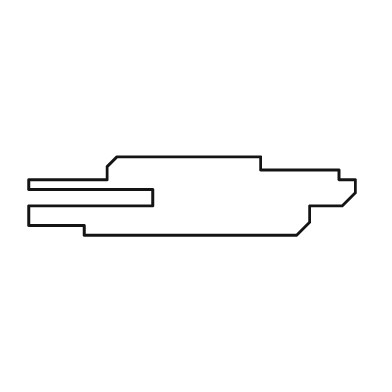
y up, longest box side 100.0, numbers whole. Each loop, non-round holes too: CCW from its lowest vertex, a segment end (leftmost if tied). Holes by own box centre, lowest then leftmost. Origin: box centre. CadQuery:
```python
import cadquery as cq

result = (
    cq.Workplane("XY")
    .moveTo(-33.0, -12.0)
    .lineTo(32.0, -12.0)
    .lineTo(36.0, -8.0)
    .lineTo(36.0, -3.0)
    .lineTo(46.0, -3.0)
    .lineTo(50.0, 1.0)
    .lineTo(50.0, 5.0)
    .lineTo(45.0, 5.0)
    .lineTo(45.0, 8.0)
    .lineTo(21.0, 8.0)
    .lineTo(21.0, 12.0)
    .lineTo(-23.0, 12.0)
    .lineTo(-26.0, 9.0)
    .lineTo(-26.0, 5.0)
    .lineTo(-50.0, 5.0)
    .lineTo(-50.0, 2.0)
    .lineTo(-12.0, 2.0)
    .lineTo(-12.0, -3.0)
    .lineTo(-50.0, -3.0)
    .lineTo(-50.0, -9.0)
    .lineTo(-33.0, -9.0)
    .close()
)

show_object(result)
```